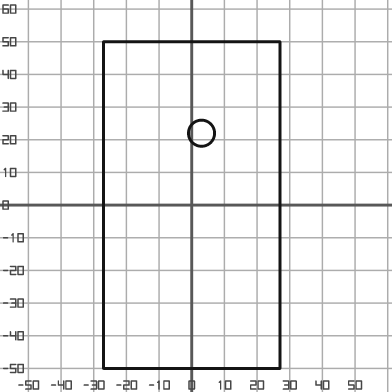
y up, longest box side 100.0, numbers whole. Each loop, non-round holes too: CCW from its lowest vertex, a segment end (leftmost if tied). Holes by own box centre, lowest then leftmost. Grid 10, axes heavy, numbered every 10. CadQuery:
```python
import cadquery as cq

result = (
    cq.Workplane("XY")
    .moveTo(-27.0, -50.0)
    .lineTo(27.0, -50.0)
    .lineTo(27.0, 50.0)
    .lineTo(-27.0, 50.0)
    .close()
    .moveTo(3.0, 22.0)
    .circle(4.0)
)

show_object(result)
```